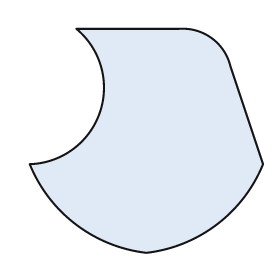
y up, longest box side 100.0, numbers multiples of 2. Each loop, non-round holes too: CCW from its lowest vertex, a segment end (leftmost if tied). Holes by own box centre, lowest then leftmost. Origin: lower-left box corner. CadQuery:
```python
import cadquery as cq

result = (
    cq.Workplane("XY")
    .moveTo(50.0, 0.0)
    .threePointArc((80.0, 12.0), (100.0, 38.0))
    .lineTo(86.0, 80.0)
    .threePointArc((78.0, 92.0), (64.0, 96.0))
    .lineTo(20.0, 96.0)
    .threePointArc((30.0, 60.0), (0.0, 38.0))
    .threePointArc((20.0, 12.0), (50.0, 0.0))
    .close()
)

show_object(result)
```